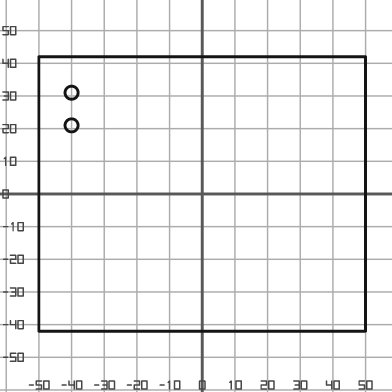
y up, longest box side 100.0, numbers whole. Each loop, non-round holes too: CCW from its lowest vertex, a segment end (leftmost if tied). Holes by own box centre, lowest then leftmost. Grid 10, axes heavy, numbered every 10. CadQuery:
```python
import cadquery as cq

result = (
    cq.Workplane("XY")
    .moveTo(-50.0, -42.0)
    .lineTo(50.0, -42.0)
    .lineTo(50.0, 42.0)
    .lineTo(-50.0, 42.0)
    .close()
    .moveTo(-40.0, 21.0)
    .circle(2.0)
    .moveTo(-40.0, 31.0)
    .circle(2.0)
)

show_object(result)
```